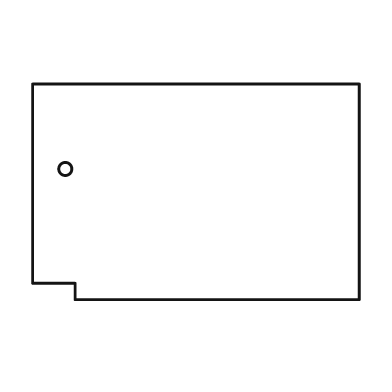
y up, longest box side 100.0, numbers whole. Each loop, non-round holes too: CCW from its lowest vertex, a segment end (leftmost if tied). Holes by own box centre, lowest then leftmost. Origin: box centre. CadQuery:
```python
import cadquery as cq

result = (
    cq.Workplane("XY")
    .moveTo(-37.0, -33.0)
    .lineTo(50.0, -33.0)
    .lineTo(50.0, 33.0)
    .lineTo(-50.0, 33.0)
    .lineTo(-50.0, -28.0)
    .lineTo(-37.0, -28.0)
    .close()
    .moveTo(-40.0, 7.0)
    .circle(2.0)
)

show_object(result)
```